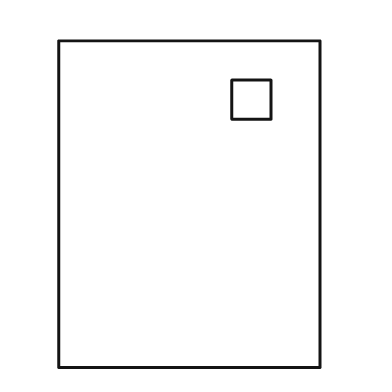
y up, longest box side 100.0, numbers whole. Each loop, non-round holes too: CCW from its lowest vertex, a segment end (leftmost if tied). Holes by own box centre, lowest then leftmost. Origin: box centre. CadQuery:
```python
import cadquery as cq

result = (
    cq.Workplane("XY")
    .moveTo(-40.0, -50.0)
    .lineTo(40.0, -50.0)
    .lineTo(40.0, 50.0)
    .lineTo(-40.0, 50.0)
    .close()
    .moveTo(13.0, 26.0)
    .lineTo(25.0, 26.0)
    .lineTo(25.0, 38.0)
    .lineTo(13.0, 38.0)
    .close()
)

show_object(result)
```